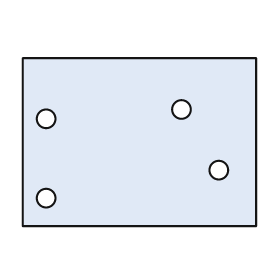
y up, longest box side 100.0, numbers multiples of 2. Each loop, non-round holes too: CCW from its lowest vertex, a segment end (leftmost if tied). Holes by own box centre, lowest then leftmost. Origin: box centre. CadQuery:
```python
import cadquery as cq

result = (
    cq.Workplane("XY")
    .moveTo(-50.0, -36.0)
    .lineTo(50.0, -36.0)
    .lineTo(50.0, 36.0)
    .lineTo(-50.0, 36.0)
    .close()
    .moveTo(-40.0, -24.0)
    .circle(4.0)
    .moveTo(34.0, -12.0)
    .circle(4.0)
    .moveTo(-40.0, 10.0)
    .circle(4.0)
    .moveTo(18.0, 14.0)
    .circle(4.0)
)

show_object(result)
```